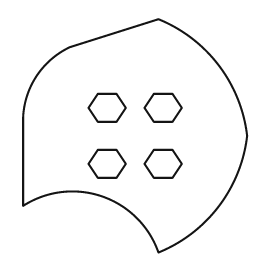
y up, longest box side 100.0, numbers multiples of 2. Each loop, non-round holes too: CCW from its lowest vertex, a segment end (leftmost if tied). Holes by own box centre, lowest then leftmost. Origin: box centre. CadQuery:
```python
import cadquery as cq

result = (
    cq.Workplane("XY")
    .moveTo(10.0, -50.0)
    .threePointArc((36.0, -30.0), (48.0, 0.0))
    .threePointArc((36.0, 30.0), (10.0, 50.0))
    .lineTo(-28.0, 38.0)
    .threePointArc((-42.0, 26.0), (-48.0, 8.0))
    .lineTo(-48.0, -30.0)
    .threePointArc((-14.0, -26.0), (10.0, -50.0))
    .close()
    .moveTo(-16.0, -18.0)
    .lineTo(-8.0, -18.0)
    .lineTo(-4.0, -12.0)
    .lineTo(-8.0, -6.0)
    .lineTo(-16.0, -6.0)
    .lineTo(-20.0, -12.0)
    .close()
    .moveTo(8.0, -18.0)
    .lineTo(16.0, -18.0)
    .lineTo(20.0, -12.0)
    .lineTo(16.0, -6.0)
    .lineTo(8.0, -6.0)
    .lineTo(4.0, -12.0)
    .close()
    .moveTo(-16.0, 6.0)
    .lineTo(-8.0, 6.0)
    .lineTo(-4.0, 12.0)
    .lineTo(-8.0, 18.0)
    .lineTo(-16.0, 18.0)
    .lineTo(-20.0, 12.0)
    .close()
    .moveTo(8.0, 6.0)
    .lineTo(16.0, 6.0)
    .lineTo(20.0, 12.0)
    .lineTo(16.0, 18.0)
    .lineTo(8.0, 18.0)
    .lineTo(4.0, 12.0)
    .close()
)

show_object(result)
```